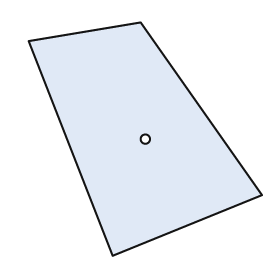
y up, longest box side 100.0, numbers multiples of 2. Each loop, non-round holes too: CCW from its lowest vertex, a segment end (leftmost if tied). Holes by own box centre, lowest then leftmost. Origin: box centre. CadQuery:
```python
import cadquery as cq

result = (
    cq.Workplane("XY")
    .moveTo(-14.0, -50.0)
    .lineTo(50.0, -24.0)
    .lineTo(-2.0, 50.0)
    .lineTo(-50.0, 42.0)
    .close()
    .moveTo(0.0, 0.0)
    .circle(2.0)
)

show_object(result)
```